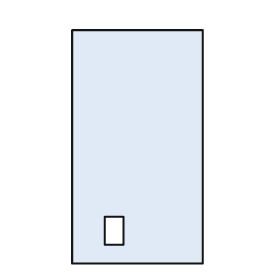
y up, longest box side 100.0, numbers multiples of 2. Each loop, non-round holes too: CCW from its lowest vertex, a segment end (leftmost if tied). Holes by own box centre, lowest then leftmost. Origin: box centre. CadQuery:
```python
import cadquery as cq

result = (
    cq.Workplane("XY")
    .moveTo(-28.0, -50.0)
    .lineTo(28.0, -50.0)
    .lineTo(28.0, 50.0)
    .lineTo(-28.0, 50.0)
    .close()
    .moveTo(-14.0, -42.0)
    .lineTo(-6.0, -42.0)
    .lineTo(-6.0, -30.0)
    .lineTo(-14.0, -30.0)
    .close()
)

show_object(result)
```